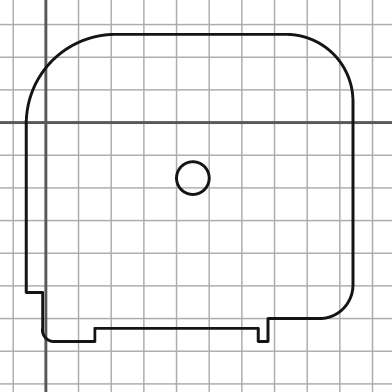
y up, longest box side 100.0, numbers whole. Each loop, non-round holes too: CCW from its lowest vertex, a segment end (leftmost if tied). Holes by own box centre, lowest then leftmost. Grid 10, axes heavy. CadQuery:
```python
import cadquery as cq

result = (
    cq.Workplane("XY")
    .moveTo(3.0, -67.0)
    .lineTo(15.0, -67.0)
    .lineTo(15.0, -63.0)
    .lineTo(65.0, -63.0)
    .lineTo(65.0, -67.0)
    .lineTo(68.0, -67.0)
    .lineTo(68.0, -60.0)
    .lineTo(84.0, -60.0)
    .threePointArc((91.0, -57.0), (94.0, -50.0))
    .lineTo(94.0, 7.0)
    .threePointArc((88.0, 21.0), (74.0, 27.0))
    .lineTo(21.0, 27.0)
    .threePointArc((2.0, 19.0), (-6.0, 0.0))
    .lineTo(-6.0, -52.0)
    .lineTo(-1.0, -52.0)
    .lineTo(-1.0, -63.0)
    .threePointArc((0.0, -66.0), (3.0, -67.0))
    .close()
    .moveTo(45.0, -17.0)
    .circle(5.0)
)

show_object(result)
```